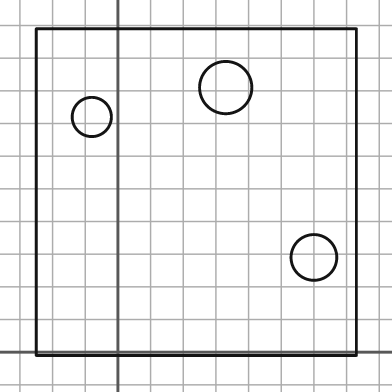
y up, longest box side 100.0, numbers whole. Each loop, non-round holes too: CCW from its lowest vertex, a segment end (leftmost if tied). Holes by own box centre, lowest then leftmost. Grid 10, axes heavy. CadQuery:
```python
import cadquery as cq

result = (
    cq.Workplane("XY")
    .moveTo(-25.0, -1.0)
    .lineTo(73.0, -1.0)
    .lineTo(73.0, 99.0)
    .lineTo(-25.0, 99.0)
    .close()
    .moveTo(60.0, 29.0)
    .circle(7.0)
    .moveTo(-8.0, 72.0)
    .circle(6.0)
    .moveTo(33.0, 81.0)
    .circle(8.0)
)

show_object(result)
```